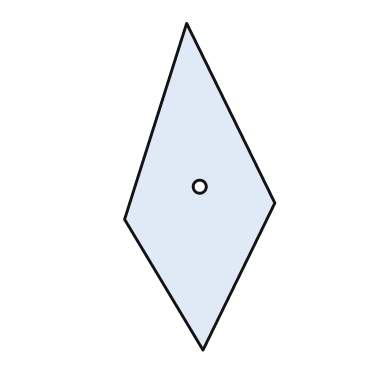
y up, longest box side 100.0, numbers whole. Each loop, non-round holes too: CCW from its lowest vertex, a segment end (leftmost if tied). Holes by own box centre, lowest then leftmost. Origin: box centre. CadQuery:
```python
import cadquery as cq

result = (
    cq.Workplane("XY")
    .moveTo(1.0, -50.0)
    .lineTo(23.0, -5.0)
    .lineTo(-4.0, 50.0)
    .lineTo(-23.0, -10.0)
    .close()
    .moveTo(0.0, 0.0)
    .circle(2.0)
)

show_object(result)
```